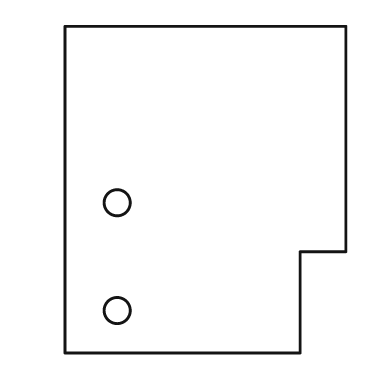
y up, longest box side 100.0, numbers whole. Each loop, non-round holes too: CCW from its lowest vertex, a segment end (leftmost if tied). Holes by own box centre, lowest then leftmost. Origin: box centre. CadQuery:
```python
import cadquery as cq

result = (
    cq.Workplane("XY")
    .moveTo(-43.0, -50.0)
    .lineTo(29.0, -50.0)
    .lineTo(29.0, -19.0)
    .lineTo(43.0, -19.0)
    .lineTo(43.0, 50.0)
    .lineTo(-43.0, 50.0)
    .close()
    .moveTo(-27.0, -37.0)
    .circle(4.0)
    .moveTo(-27.0, -4.0)
    .circle(4.0)
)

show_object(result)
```